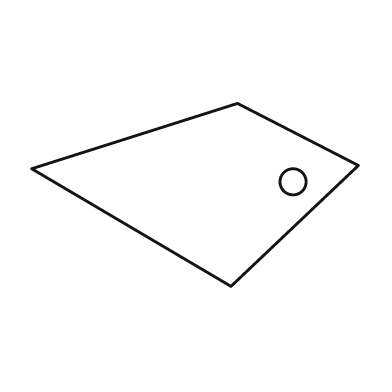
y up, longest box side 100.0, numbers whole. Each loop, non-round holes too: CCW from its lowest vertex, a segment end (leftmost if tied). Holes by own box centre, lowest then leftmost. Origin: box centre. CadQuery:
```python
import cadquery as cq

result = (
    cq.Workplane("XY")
    .moveTo(11.0, -28.0)
    .lineTo(50.0, 9.0)
    .lineTo(13.0, 28.0)
    .lineTo(-50.0, 8.0)
    .close()
    .moveTo(30.0, 4.0)
    .circle(4.0)
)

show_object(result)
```